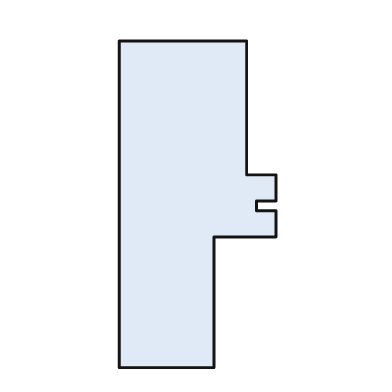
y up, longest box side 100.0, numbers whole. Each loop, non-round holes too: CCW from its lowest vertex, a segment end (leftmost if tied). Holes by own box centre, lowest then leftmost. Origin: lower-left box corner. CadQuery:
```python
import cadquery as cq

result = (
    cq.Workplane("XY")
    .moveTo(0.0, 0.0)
    .lineTo(29.0, 0.0)
    .lineTo(29.0, 40.0)
    .lineTo(48.0, 40.0)
    .lineTo(48.0, 48.0)
    .lineTo(42.0, 48.0)
    .lineTo(42.0, 51.0)
    .lineTo(48.0, 51.0)
    .lineTo(48.0, 59.0)
    .lineTo(39.0, 59.0)
    .lineTo(39.0, 100.0)
    .lineTo(0.0, 100.0)
    .close()
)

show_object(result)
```